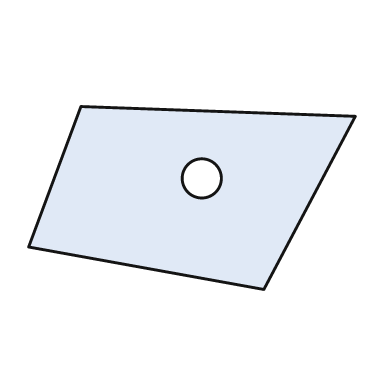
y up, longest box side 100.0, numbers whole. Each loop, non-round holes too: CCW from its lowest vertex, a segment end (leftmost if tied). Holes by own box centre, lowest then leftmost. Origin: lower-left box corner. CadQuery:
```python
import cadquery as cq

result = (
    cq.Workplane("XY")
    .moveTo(72.0, 0.0)
    .lineTo(100.0, 53.0)
    .lineTo(16.0, 56.0)
    .lineTo(0.0, 13.0)
    .close()
    .moveTo(53.0, 34.0)
    .circle(6.0)
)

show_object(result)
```